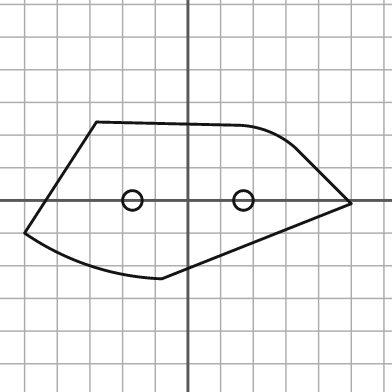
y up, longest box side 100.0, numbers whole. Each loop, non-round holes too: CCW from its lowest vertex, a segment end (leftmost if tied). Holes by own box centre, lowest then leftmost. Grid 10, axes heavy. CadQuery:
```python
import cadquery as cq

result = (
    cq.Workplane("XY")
    .moveTo(-8.0, -24.0)
    .lineTo(50.0, -1.0)
    .lineTo(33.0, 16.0)
    .threePointArc((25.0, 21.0), (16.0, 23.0))
    .lineTo(-28.0, 24.0)
    .lineTo(-50.0, -10.0)
    .threePointArc((-30.0, -20.0), (-8.0, -24.0))
    .close()
    .moveTo(-17.0, 0.0)
    .circle(3.0)
    .moveTo(17.0, 0.0)
    .circle(3.0)
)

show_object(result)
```